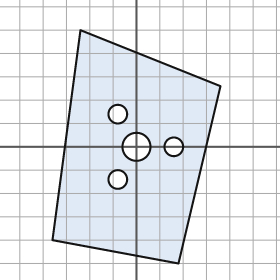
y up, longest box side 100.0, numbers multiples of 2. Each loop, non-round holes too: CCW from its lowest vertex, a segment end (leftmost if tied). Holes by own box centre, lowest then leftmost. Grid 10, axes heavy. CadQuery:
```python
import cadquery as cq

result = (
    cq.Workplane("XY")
    .moveTo(18.0, -50.0)
    .lineTo(36.0, 26.0)
    .lineTo(-24.0, 50.0)
    .lineTo(-36.0, -40.0)
    .close()
    .moveTo(-8.0, -14.0)
    .circle(4.0)
    .moveTo(0.0, 0.0)
    .circle(6.0)
    .moveTo(16.0, 0.0)
    .circle(4.0)
    .moveTo(-8.0, 14.0)
    .circle(4.0)
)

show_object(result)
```